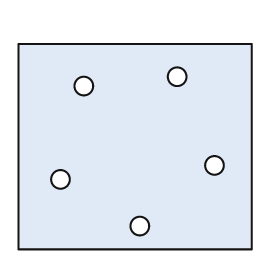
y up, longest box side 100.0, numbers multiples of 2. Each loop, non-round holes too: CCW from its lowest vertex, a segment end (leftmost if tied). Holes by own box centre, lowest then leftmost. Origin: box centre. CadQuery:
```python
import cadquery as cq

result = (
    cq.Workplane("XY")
    .moveTo(-50.0, -44.0)
    .lineTo(50.0, -44.0)
    .lineTo(50.0, 44.0)
    .lineTo(-50.0, 44.0)
    .close()
    .moveTo(2.0, -34.0)
    .circle(4.0)
    .moveTo(-32.0, -14.0)
    .circle(4.0)
    .moveTo(34.0, -8.0)
    .circle(4.0)
    .moveTo(-22.0, 26.0)
    .circle(4.0)
    .moveTo(18.0, 30.0)
    .circle(4.0)
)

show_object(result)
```